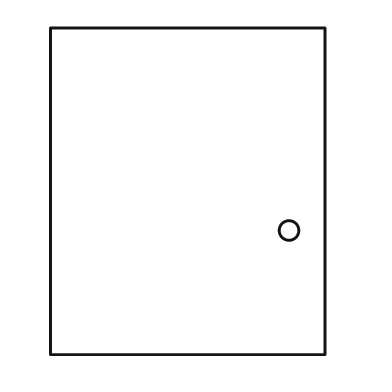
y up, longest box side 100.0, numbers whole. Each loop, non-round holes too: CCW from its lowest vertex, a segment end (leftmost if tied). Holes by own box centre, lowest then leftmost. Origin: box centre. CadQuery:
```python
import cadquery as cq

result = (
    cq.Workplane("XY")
    .moveTo(-42.0, -50.0)
    .lineTo(42.0, -50.0)
    .lineTo(42.0, 50.0)
    .lineTo(-42.0, 50.0)
    .close()
    .moveTo(31.0, -12.0)
    .circle(3.0)
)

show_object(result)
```